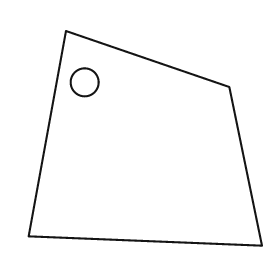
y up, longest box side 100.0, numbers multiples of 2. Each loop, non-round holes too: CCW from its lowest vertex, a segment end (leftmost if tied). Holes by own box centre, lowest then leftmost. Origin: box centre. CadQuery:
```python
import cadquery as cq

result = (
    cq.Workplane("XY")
    .moveTo(50.0, -46.0)
    .lineTo(36.0, 22.0)
    .lineTo(-34.0, 46.0)
    .lineTo(-50.0, -42.0)
    .close()
    .moveTo(-26.0, 24.0)
    .circle(6.0)
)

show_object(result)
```